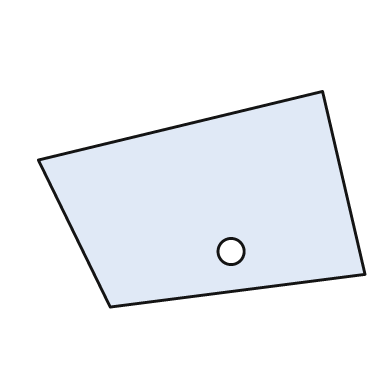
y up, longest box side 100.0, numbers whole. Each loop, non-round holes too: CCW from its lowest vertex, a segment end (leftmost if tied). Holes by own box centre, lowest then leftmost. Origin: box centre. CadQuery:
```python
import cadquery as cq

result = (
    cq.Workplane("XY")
    .moveTo(-28.0, -33.0)
    .lineTo(50.0, -23.0)
    .lineTo(37.0, 33.0)
    .lineTo(-50.0, 12.0)
    .close()
    .moveTo(9.0, -16.0)
    .circle(4.0)
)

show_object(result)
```